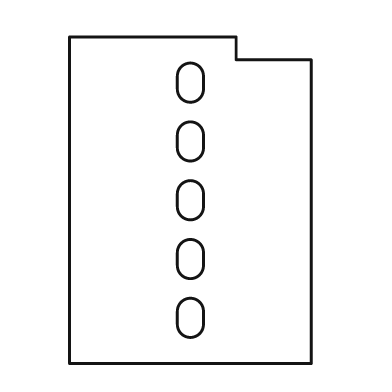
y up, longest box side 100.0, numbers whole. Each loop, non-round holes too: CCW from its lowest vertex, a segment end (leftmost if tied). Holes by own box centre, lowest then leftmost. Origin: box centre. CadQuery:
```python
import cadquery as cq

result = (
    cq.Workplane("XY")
    .moveTo(-37.0, -50.0)
    .lineTo(37.0, -50.0)
    .lineTo(37.0, 43.0)
    .lineTo(14.0, 43.0)
    .lineTo(14.0, 50.0)
    .lineTo(-37.0, 50.0)
    .close()
    .moveTo(-4.0, -38.0)
    .threePointArc((0.0, -42.0), (4.0, -38.0))
    .lineTo(4.0, -34.0)
    .threePointArc((0.0, -30.0), (-4.0, -34.0))
    .close()
    .moveTo(-4.0, -20.0)
    .threePointArc((0.0, -24.0), (4.0, -20.0))
    .lineTo(4.0, -16.0)
    .threePointArc((0.0, -12.0), (-4.0, -16.0))
    .close()
    .moveTo(-4.0, -2.0)
    .threePointArc((0.0, -6.0), (4.0, -2.0))
    .lineTo(4.0, 2.0)
    .threePointArc((0.0, 6.0), (-4.0, 2.0))
    .close()
    .moveTo(-4.0, 16.0)
    .threePointArc((0.0, 12.0), (4.0, 16.0))
    .lineTo(4.0, 20.0)
    .threePointArc((0.0, 24.0), (-4.0, 20.0))
    .close()
    .moveTo(-4.0, 34.0)
    .threePointArc((0.0, 30.0), (4.0, 34.0))
    .lineTo(4.0, 38.0)
    .threePointArc((0.0, 42.0), (-4.0, 38.0))
    .close()
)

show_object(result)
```